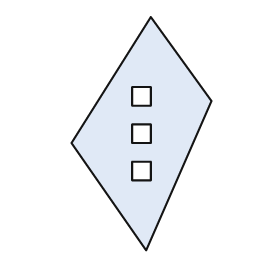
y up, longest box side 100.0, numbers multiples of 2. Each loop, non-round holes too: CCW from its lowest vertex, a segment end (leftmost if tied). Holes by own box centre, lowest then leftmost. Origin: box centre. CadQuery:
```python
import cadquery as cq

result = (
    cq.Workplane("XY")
    .moveTo(2.0, -50.0)
    .lineTo(30.0, 14.0)
    .lineTo(4.0, 50.0)
    .lineTo(-30.0, -4.0)
    .close()
    .moveTo(-4.0, -20.0)
    .lineTo(4.0, -20.0)
    .lineTo(4.0, -12.0)
    .lineTo(-4.0, -12.0)
    .close()
    .moveTo(-4.0, -4.0)
    .lineTo(4.0, -4.0)
    .lineTo(4.0, 4.0)
    .lineTo(-4.0, 4.0)
    .close()
    .moveTo(-4.0, 12.0)
    .lineTo(4.0, 12.0)
    .lineTo(4.0, 20.0)
    .lineTo(-4.0, 20.0)
    .close()
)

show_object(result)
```